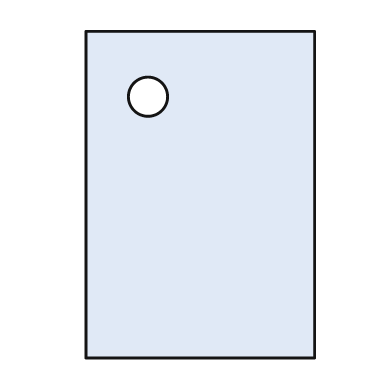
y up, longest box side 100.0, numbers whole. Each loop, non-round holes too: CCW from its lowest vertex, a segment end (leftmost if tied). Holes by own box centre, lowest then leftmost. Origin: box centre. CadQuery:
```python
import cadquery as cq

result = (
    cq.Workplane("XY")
    .moveTo(-35.0, -50.0)
    .lineTo(35.0, -50.0)
    .lineTo(35.0, 50.0)
    .lineTo(-35.0, 50.0)
    .close()
    .moveTo(-16.0, 30.0)
    .circle(6.0)
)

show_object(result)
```